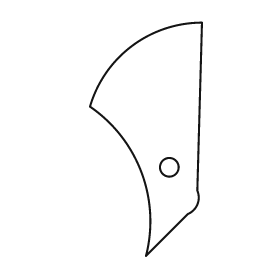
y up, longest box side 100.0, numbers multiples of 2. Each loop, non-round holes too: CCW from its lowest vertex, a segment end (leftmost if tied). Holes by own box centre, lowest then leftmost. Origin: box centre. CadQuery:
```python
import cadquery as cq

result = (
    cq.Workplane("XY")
    .moveTo(0.0, -50.0)
    .lineTo(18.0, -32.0)
    .threePointArc((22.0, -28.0), (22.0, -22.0))
    .lineTo(24.0, 50.0)
    .threePointArc((-6.0, 40.0), (-24.0, 14.0))
    .threePointArc((-2.0, -14.0), (0.0, -50.0))
    .close()
    .moveTo(10.0, -12.0)
    .circle(4.0)
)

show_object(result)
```